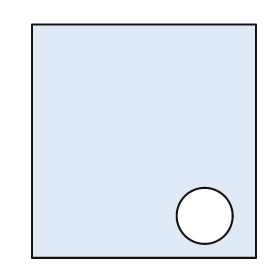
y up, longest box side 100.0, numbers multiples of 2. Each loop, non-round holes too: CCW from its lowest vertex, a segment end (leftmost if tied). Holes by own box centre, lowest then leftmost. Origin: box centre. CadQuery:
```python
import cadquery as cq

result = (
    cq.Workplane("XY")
    .moveTo(-48.0, -50.0)
    .lineTo(48.0, -50.0)
    .lineTo(48.0, 50.0)
    .lineTo(-48.0, 50.0)
    .close()
    .moveTo(26.0, -32.0)
    .circle(12.0)
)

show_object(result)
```